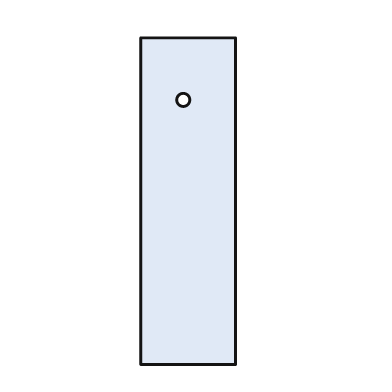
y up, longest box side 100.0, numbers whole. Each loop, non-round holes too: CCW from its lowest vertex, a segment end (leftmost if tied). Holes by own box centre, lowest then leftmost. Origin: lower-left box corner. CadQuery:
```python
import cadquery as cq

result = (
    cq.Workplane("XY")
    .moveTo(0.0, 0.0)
    .lineTo(29.0, 0.0)
    .lineTo(29.0, 100.0)
    .lineTo(0.0, 100.0)
    .close()
    .moveTo(13.0, 81.0)
    .circle(2.0)
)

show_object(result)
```